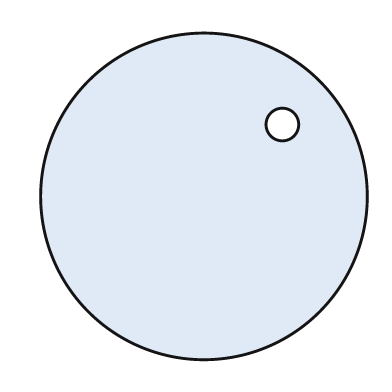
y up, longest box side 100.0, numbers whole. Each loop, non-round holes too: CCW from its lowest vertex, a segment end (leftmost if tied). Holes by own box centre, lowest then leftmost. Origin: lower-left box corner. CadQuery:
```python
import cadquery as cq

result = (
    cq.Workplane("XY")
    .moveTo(50.0, 50.0)
    .circle(50.0)
    .moveTo(74.0, 72.0)
    .circle(5.0)
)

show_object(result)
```